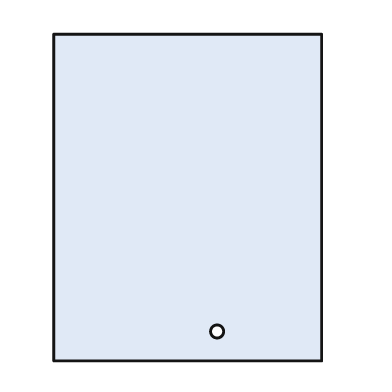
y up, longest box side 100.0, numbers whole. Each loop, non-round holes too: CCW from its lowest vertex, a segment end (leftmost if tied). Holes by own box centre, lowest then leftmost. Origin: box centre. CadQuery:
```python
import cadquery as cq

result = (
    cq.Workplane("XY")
    .moveTo(-41.0, -50.0)
    .lineTo(41.0, -50.0)
    .lineTo(41.0, 50.0)
    .lineTo(-41.0, 50.0)
    .close()
    .moveTo(9.0, -41.0)
    .circle(2.0)
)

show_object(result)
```